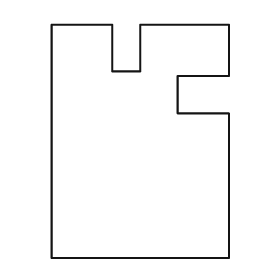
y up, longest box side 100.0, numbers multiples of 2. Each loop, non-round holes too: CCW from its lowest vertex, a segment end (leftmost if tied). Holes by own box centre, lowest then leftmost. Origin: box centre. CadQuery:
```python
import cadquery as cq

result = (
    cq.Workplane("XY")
    .moveTo(-38.0, -50.0)
    .lineTo(38.0, -50.0)
    .lineTo(38.0, 12.0)
    .lineTo(16.0, 12.0)
    .lineTo(16.0, 28.0)
    .lineTo(38.0, 28.0)
    .lineTo(38.0, 50.0)
    .lineTo(0.0, 50.0)
    .lineTo(0.0, 30.0)
    .lineTo(-12.0, 30.0)
    .lineTo(-12.0, 50.0)
    .lineTo(-38.0, 50.0)
    .close()
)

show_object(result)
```